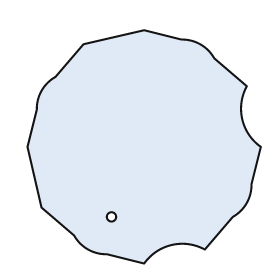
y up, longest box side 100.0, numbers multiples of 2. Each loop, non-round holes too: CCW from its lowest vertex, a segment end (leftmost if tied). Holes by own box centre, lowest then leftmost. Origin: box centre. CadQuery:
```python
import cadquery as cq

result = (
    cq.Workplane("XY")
    .moveTo(0.0, -50.0)
    .threePointArc((12.0, -42.0), (26.0, -44.0))
    .lineTo(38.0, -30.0)
    .threePointArc((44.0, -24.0), (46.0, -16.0))
    .lineTo(50.0, 0.0)
    .threePointArc((42.0, 12.0), (44.0, 26.0))
    .lineTo(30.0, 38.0)
    .threePointArc((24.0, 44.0), (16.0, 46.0))
    .lineTo(0.0, 50.0)
    .lineTo(-26.0, 44.0)
    .lineTo(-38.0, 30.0)
    .threePointArc((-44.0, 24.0), (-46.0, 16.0))
    .lineTo(-50.0, 0.0)
    .lineTo(-44.0, -26.0)
    .lineTo(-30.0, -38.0)
    .threePointArc((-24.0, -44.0), (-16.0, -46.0))
    .close()
    .moveTo(-14.0, -30.0)
    .circle(2.0)
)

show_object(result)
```